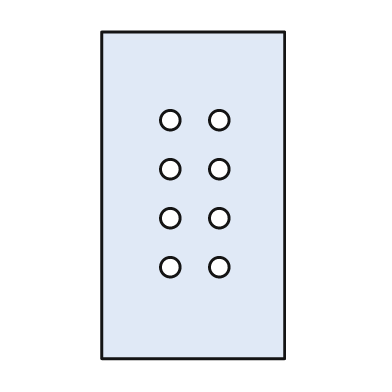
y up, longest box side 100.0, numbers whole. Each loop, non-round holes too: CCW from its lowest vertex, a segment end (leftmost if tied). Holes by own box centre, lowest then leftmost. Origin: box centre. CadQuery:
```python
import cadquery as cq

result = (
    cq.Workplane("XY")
    .moveTo(-28.0, -50.0)
    .lineTo(28.0, -50.0)
    .lineTo(28.0, 50.0)
    .lineTo(-28.0, 50.0)
    .close()
    .moveTo(-7.0, -22.0)
    .circle(3.0)
    .moveTo(8.0, -22.0)
    .circle(3.0)
    .moveTo(-7.0, -7.0)
    .circle(3.0)
    .moveTo(8.0, -7.0)
    .circle(3.0)
    .moveTo(-7.0, 8.0)
    .circle(3.0)
    .moveTo(8.0, 8.0)
    .circle(3.0)
    .moveTo(-7.0, 23.0)
    .circle(3.0)
    .moveTo(8.0, 23.0)
    .circle(3.0)
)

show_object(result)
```